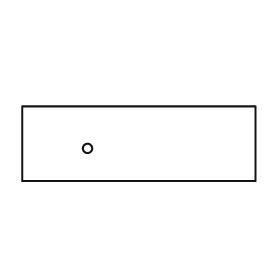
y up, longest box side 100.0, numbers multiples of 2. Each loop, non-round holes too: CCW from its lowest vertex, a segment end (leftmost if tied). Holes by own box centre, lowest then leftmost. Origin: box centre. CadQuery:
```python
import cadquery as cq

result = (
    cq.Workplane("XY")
    .moveTo(-50.0, -16.0)
    .lineTo(50.0, -16.0)
    .lineTo(50.0, 16.0)
    .lineTo(-50.0, 16.0)
    .close()
    .moveTo(-22.0, -2.0)
    .circle(2.0)
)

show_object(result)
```